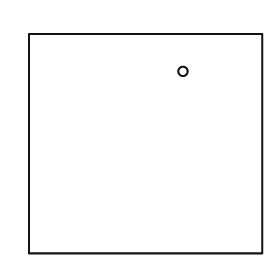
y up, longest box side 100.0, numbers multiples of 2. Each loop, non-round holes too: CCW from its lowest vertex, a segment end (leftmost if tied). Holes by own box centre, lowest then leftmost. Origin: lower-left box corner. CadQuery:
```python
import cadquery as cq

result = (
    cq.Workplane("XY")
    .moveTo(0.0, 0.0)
    .lineTo(100.0, 0.0)
    .lineTo(100.0, 94.0)
    .lineTo(0.0, 94.0)
    .close()
    .moveTo(66.0, 78.0)
    .circle(2.0)
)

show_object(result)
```